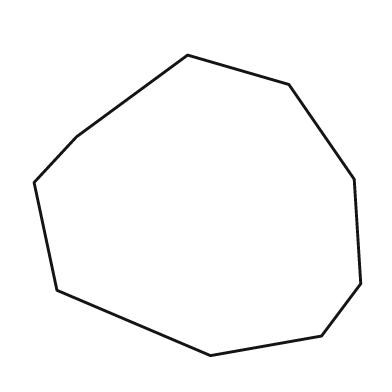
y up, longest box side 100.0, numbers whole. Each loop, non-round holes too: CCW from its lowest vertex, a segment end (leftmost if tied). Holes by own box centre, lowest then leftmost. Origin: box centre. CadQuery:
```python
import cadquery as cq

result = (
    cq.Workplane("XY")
    .moveTo(4.0, -46.0)
    .lineTo(38.0, -40.0)
    .lineTo(50.0, -24.0)
    .lineTo(48.0, 8.0)
    .lineTo(28.0, 37.0)
    .lineTo(-3.0, 46.0)
    .lineTo(-37.0, 21.0)
    .lineTo(-50.0, 7.0)
    .lineTo(-43.0, -26.0)
    .close()
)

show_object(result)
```